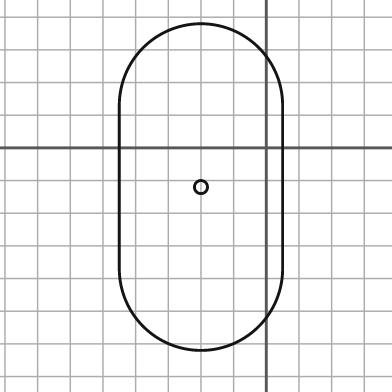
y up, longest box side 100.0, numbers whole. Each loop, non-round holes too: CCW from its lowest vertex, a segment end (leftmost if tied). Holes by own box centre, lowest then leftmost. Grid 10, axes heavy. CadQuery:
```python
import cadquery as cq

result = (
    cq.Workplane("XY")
    .moveTo(-45.0, -37.0)
    .threePointArc((-20.0, -62.0), (5.0, -37.0))
    .lineTo(5.0, 13.0)
    .threePointArc((-20.0, 38.0), (-45.0, 13.0))
    .close()
    .moveTo(-20.0, -12.0)
    .circle(2.0)
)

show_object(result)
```